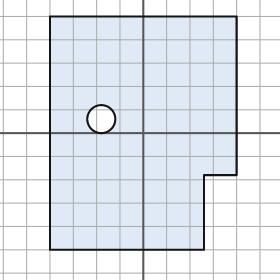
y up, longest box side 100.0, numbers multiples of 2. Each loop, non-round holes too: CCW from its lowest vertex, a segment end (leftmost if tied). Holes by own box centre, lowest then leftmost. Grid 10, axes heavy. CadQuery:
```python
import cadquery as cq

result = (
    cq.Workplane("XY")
    .moveTo(-40.0, -50.0)
    .lineTo(26.0, -50.0)
    .lineTo(26.0, -18.0)
    .lineTo(40.0, -18.0)
    .lineTo(40.0, 50.0)
    .lineTo(-40.0, 50.0)
    .close()
    .moveTo(-18.0, 6.0)
    .circle(6.0)
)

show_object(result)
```